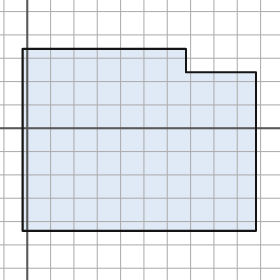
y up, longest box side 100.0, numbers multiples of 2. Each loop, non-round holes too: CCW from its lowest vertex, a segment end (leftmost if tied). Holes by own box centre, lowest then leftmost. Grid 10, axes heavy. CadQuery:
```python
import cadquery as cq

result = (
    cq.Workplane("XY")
    .moveTo(-2.0, -44.0)
    .lineTo(98.0, -44.0)
    .lineTo(98.0, 24.0)
    .lineTo(68.0, 24.0)
    .lineTo(68.0, 34.0)
    .lineTo(-2.0, 34.0)
    .close()
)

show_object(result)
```